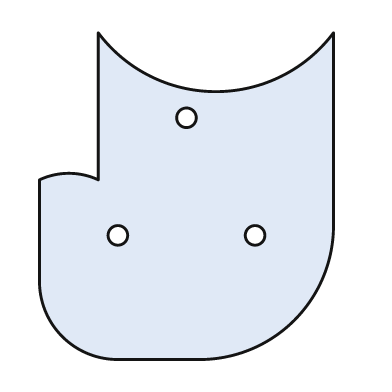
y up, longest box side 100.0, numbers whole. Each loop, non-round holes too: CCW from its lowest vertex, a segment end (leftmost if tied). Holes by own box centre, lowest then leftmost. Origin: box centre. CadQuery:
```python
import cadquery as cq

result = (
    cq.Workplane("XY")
    .moveTo(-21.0, -50.0)
    .lineTo(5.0, -50.0)
    .threePointArc((33.0, -38.0), (45.0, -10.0))
    .lineTo(45.0, 50.0)
    .threePointArc((9.0, 32.0), (-27.0, 50.0))
    .lineTo(-27.0, 5.0)
    .threePointArc((-36.0, 7.0), (-45.0, 5.0))
    .lineTo(-45.0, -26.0)
    .threePointArc((-38.0, -43.0), (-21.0, -50.0))
    .close()
    .moveTo(-21.0, -12.0)
    .circle(3.0)
    .moveTo(21.0, -12.0)
    .circle(3.0)
    .moveTo(0.0, 24.0)
    .circle(3.0)
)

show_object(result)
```